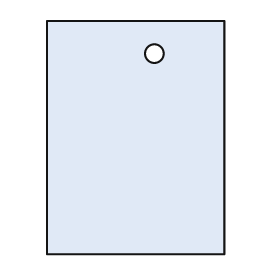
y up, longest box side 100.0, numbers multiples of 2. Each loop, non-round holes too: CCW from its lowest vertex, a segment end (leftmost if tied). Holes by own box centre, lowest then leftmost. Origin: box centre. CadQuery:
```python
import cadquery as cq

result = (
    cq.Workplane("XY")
    .moveTo(-38.0, -50.0)
    .lineTo(38.0, -50.0)
    .lineTo(38.0, 50.0)
    .lineTo(-38.0, 50.0)
    .close()
    .moveTo(8.0, 36.0)
    .circle(4.0)
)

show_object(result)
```